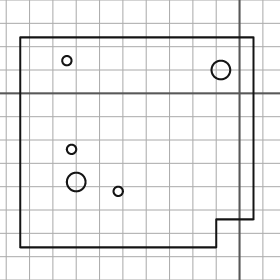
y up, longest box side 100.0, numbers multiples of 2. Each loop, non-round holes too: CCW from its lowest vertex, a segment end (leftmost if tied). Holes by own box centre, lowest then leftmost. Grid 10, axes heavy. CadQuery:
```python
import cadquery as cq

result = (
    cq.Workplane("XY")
    .moveTo(-94.0, -66.0)
    .lineTo(-10.0, -66.0)
    .lineTo(-10.0, -54.0)
    .lineTo(6.0, -54.0)
    .lineTo(6.0, 24.0)
    .lineTo(-94.0, 24.0)
    .close()
    .moveTo(-52.0, -42.0)
    .circle(2.0)
    .moveTo(-70.0, -38.0)
    .circle(4.0)
    .moveTo(-72.0, -24.0)
    .circle(2.0)
    .moveTo(-8.0, 10.0)
    .circle(4.0)
    .moveTo(-74.0, 14.0)
    .circle(2.0)
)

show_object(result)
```